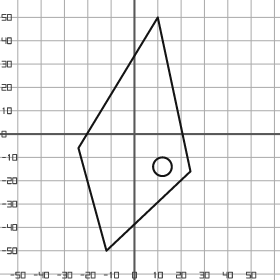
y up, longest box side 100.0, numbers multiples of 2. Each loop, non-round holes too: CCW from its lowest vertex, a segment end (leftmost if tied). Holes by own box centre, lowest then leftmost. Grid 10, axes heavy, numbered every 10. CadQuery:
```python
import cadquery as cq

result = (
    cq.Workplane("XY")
    .moveTo(-12.0, -50.0)
    .lineTo(24.0, -16.0)
    .lineTo(10.0, 50.0)
    .lineTo(-24.0, -6.0)
    .close()
    .moveTo(12.0, -14.0)
    .circle(4.0)
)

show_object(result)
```